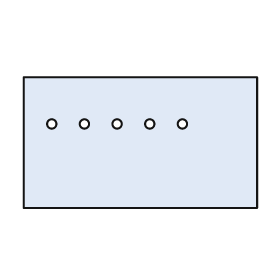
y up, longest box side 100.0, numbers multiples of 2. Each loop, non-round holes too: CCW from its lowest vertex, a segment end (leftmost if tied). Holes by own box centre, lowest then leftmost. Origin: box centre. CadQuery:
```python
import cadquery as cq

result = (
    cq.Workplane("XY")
    .moveTo(-50.0, -28.0)
    .lineTo(50.0, -28.0)
    .lineTo(50.0, 28.0)
    .lineTo(-50.0, 28.0)
    .close()
    .moveTo(-38.0, 8.0)
    .circle(2.0)
    .moveTo(-24.0, 8.0)
    .circle(2.0)
    .moveTo(-10.0, 8.0)
    .circle(2.0)
    .moveTo(4.0, 8.0)
    .circle(2.0)
    .moveTo(18.0, 8.0)
    .circle(2.0)
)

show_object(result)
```